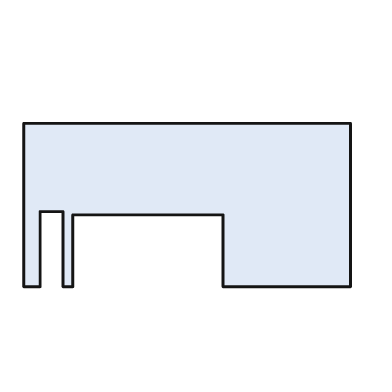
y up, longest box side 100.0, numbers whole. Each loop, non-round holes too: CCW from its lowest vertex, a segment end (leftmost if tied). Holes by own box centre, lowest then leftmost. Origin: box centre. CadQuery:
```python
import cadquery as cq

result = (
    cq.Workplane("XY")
    .moveTo(-50.0, -25.0)
    .lineTo(-45.0, -25.0)
    .lineTo(-45.0, -2.0)
    .lineTo(-38.0, -2.0)
    .lineTo(-38.0, -25.0)
    .lineTo(-35.0, -25.0)
    .lineTo(-35.0, -3.0)
    .lineTo(11.0, -3.0)
    .lineTo(11.0, -25.0)
    .lineTo(50.0, -25.0)
    .lineTo(50.0, 25.0)
    .lineTo(-50.0, 25.0)
    .close()
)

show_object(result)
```